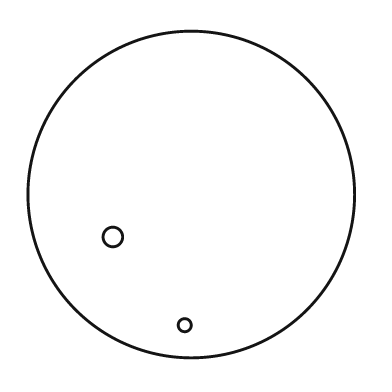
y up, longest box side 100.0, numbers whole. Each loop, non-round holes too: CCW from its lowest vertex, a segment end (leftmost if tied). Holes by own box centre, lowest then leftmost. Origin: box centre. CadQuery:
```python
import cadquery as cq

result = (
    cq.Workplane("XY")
    .moveTo(0.0, 0.0)
    .circle(50.0)
    .moveTo(-2.0, -40.0)
    .circle(2.0)
    .moveTo(-24.0, -13.0)
    .circle(3.0)
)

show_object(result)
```